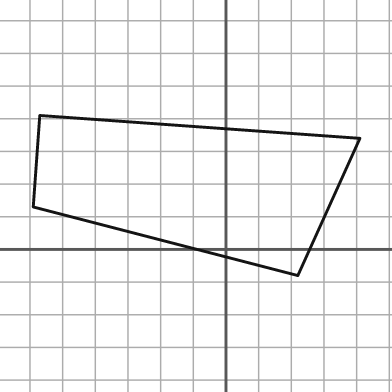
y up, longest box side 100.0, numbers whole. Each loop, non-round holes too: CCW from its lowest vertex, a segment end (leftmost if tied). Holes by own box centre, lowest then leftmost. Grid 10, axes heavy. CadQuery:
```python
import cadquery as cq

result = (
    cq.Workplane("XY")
    .moveTo(22.0, -8.0)
    .lineTo(41.0, 34.0)
    .lineTo(-57.0, 41.0)
    .lineTo(-59.0, 13.0)
    .close()
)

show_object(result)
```